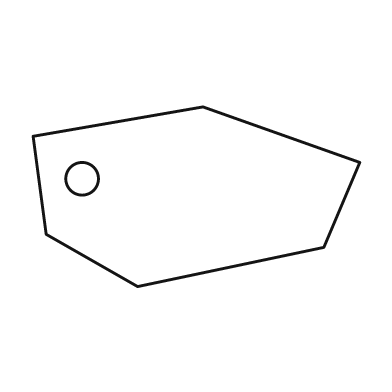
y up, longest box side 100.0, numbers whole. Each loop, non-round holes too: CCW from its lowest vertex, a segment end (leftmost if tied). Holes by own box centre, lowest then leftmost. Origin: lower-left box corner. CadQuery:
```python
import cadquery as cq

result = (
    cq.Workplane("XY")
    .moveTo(32.0, 0.0)
    .lineTo(89.0, 12.0)
    .lineTo(100.0, 38.0)
    .lineTo(52.0, 55.0)
    .lineTo(0.0, 46.0)
    .lineTo(4.0, 16.0)
    .close()
    .moveTo(15.0, 33.0)
    .circle(5.0)
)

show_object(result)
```